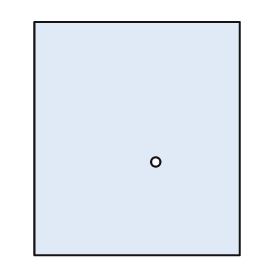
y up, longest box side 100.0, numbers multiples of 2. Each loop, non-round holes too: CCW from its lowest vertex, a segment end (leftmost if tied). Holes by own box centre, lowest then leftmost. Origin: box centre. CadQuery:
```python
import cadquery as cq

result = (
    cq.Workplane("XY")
    .moveTo(-44.0, -50.0)
    .lineTo(44.0, -50.0)
    .lineTo(44.0, 50.0)
    .lineTo(-44.0, 50.0)
    .close()
    .moveTo(8.0, -10.0)
    .circle(2.0)
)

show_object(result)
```